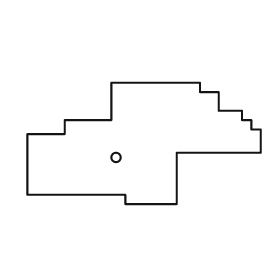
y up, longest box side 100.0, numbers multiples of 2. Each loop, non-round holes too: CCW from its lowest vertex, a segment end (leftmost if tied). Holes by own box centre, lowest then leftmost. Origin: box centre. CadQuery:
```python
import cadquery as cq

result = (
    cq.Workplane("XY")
    .moveTo(-8.0, -26.0)
    .lineTo(14.0, -26.0)
    .lineTo(14.0, -4.0)
    .lineTo(50.0, -4.0)
    .lineTo(50.0, 6.0)
    .lineTo(46.0, 6.0)
    .lineTo(46.0, 10.0)
    .lineTo(42.0, 10.0)
    .lineTo(42.0, 14.0)
    .lineTo(32.0, 14.0)
    .lineTo(32.0, 22.0)
    .lineTo(24.0, 22.0)
    .lineTo(24.0, 26.0)
    .lineTo(-14.0, 26.0)
    .lineTo(-14.0, 10.0)
    .lineTo(-34.0, 10.0)
    .lineTo(-34.0, 4.0)
    .lineTo(-50.0, 4.0)
    .lineTo(-50.0, -22.0)
    .lineTo(-8.0, -22.0)
    .close()
    .moveTo(-12.0, -6.0)
    .circle(2.0)
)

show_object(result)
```